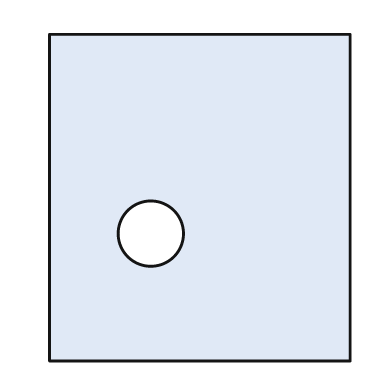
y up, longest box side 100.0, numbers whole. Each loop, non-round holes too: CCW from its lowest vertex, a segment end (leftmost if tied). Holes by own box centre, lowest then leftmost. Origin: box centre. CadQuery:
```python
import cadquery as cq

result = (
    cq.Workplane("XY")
    .moveTo(-46.0, -50.0)
    .lineTo(46.0, -50.0)
    .lineTo(46.0, 50.0)
    .lineTo(-46.0, 50.0)
    .close()
    .moveTo(-15.0, -11.0)
    .circle(10.0)
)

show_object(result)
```